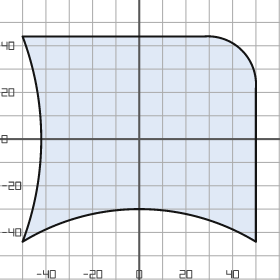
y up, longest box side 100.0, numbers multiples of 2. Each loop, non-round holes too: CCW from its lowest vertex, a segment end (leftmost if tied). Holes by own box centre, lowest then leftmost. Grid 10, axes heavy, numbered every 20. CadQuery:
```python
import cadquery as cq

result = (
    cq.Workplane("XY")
    .moveTo(-50.0, -44.0)
    .threePointArc((0.0, -30.0), (50.0, -44.0))
    .lineTo(50.0, 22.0)
    .threePointArc((44.0, 38.0), (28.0, 44.0))
    .lineTo(-50.0, 44.0)
    .threePointArc((-42.0, 0.0), (-50.0, -44.0))
    .close()
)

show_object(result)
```